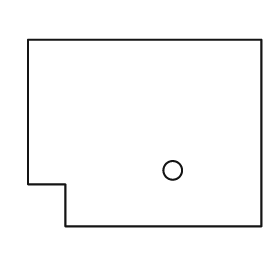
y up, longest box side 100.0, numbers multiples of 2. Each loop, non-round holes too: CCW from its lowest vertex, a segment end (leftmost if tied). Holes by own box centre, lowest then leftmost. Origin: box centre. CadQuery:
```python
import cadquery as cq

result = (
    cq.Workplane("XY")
    .moveTo(-34.0, -40.0)
    .lineTo(50.0, -40.0)
    .lineTo(50.0, 40.0)
    .lineTo(-50.0, 40.0)
    .lineTo(-50.0, -22.0)
    .lineTo(-34.0, -22.0)
    .close()
    .moveTo(12.0, -16.0)
    .circle(4.0)
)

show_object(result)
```